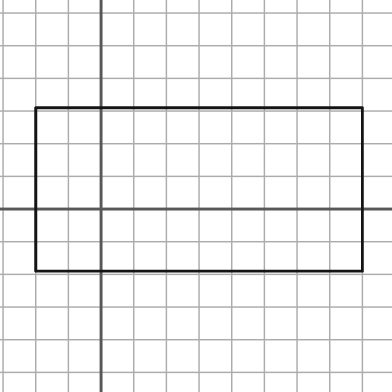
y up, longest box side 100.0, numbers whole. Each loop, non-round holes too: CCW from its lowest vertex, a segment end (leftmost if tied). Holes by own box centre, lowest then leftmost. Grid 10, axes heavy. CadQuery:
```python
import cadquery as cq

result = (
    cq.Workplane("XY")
    .moveTo(-20.0, -19.0)
    .lineTo(80.0, -19.0)
    .lineTo(80.0, 31.0)
    .lineTo(-20.0, 31.0)
    .close()
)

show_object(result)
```